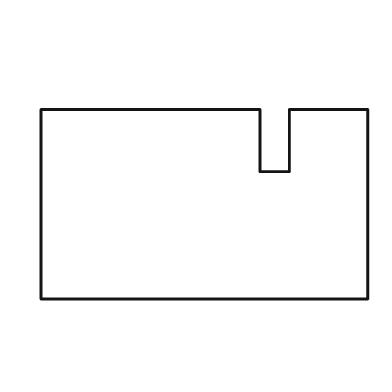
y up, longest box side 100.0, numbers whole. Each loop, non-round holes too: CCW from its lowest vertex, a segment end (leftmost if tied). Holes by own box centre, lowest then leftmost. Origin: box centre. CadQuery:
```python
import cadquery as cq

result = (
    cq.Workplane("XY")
    .moveTo(-50.0, -29.0)
    .lineTo(50.0, -29.0)
    .lineTo(50.0, 29.0)
    .lineTo(26.0, 29.0)
    .lineTo(26.0, 10.0)
    .lineTo(17.0, 10.0)
    .lineTo(17.0, 29.0)
    .lineTo(-50.0, 29.0)
    .close()
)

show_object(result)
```